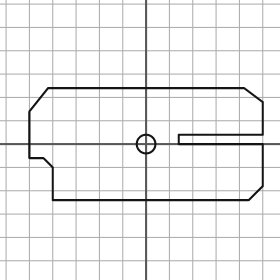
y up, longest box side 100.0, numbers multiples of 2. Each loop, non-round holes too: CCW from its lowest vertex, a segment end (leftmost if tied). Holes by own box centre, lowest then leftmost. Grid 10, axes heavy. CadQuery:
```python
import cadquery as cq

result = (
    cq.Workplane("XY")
    .moveTo(-40.0, -24.0)
    .lineTo(44.0, -24.0)
    .lineTo(50.0, -18.0)
    .lineTo(50.0, 0.0)
    .lineTo(14.0, 0.0)
    .lineTo(14.0, 4.0)
    .lineTo(50.0, 4.0)
    .lineTo(50.0, 18.0)
    .lineTo(42.0, 24.0)
    .lineTo(-42.0, 24.0)
    .lineTo(-50.0, 14.0)
    .lineTo(-50.0, -6.0)
    .lineTo(-44.0, -6.0)
    .lineTo(-40.0, -10.0)
    .close()
    .moveTo(0.0, 0.0)
    .circle(4.0)
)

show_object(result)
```